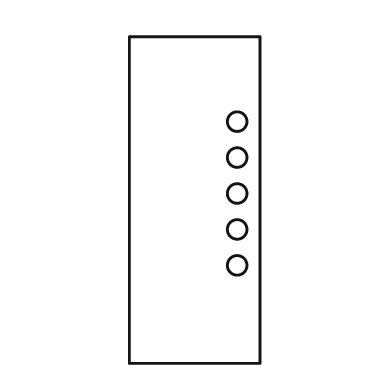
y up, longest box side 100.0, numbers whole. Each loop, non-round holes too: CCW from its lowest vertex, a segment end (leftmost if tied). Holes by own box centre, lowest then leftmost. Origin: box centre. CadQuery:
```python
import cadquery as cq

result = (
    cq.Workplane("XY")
    .moveTo(-20.0, -50.0)
    .lineTo(20.0, -50.0)
    .lineTo(20.0, 50.0)
    .lineTo(-20.0, 50.0)
    .close()
    .moveTo(13.0, -20.0)
    .circle(3.0)
    .moveTo(13.0, -9.0)
    .circle(3.0)
    .moveTo(13.0, 2.0)
    .circle(3.0)
    .moveTo(13.0, 13.0)
    .circle(3.0)
    .moveTo(13.0, 24.0)
    .circle(3.0)
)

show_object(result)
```